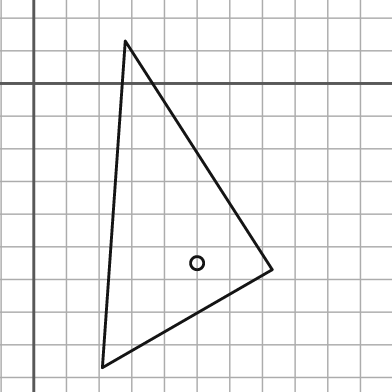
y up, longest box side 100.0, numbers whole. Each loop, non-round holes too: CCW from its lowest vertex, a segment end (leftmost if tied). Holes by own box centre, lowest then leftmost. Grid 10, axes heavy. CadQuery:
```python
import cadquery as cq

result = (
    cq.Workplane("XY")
    .moveTo(21.0, -87.0)
    .lineTo(73.0, -57.0)
    .lineTo(28.0, 13.0)
    .close()
    .moveTo(50.0, -55.0)
    .circle(2.0)
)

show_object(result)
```